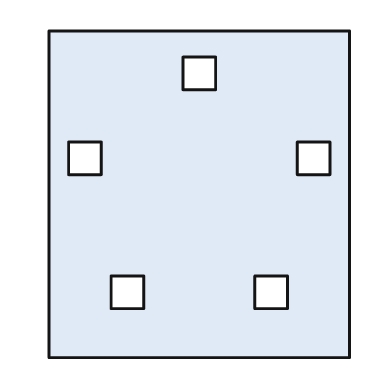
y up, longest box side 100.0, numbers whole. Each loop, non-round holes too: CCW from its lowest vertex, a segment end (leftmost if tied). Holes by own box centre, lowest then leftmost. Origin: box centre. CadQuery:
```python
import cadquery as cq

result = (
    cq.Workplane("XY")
    .moveTo(-46.0, -50.0)
    .lineTo(46.0, -50.0)
    .lineTo(46.0, 50.0)
    .lineTo(-46.0, 50.0)
    .close()
    .moveTo(-27.0, -35.0)
    .lineTo(-17.0, -35.0)
    .lineTo(-17.0, -25.0)
    .lineTo(-27.0, -25.0)
    .close()
    .moveTo(17.0, -35.0)
    .lineTo(27.0, -35.0)
    .lineTo(27.0, -25.0)
    .lineTo(17.0, -25.0)
    .close()
    .moveTo(-40.0, 6.0)
    .lineTo(-30.0, 6.0)
    .lineTo(-30.0, 16.0)
    .lineTo(-40.0, 16.0)
    .close()
    .moveTo(30.0, 6.0)
    .lineTo(40.0, 6.0)
    .lineTo(40.0, 16.0)
    .lineTo(30.0, 16.0)
    .close()
    .moveTo(-5.0, 32.0)
    .lineTo(5.0, 32.0)
    .lineTo(5.0, 42.0)
    .lineTo(-5.0, 42.0)
    .close()
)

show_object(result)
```